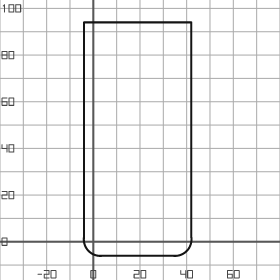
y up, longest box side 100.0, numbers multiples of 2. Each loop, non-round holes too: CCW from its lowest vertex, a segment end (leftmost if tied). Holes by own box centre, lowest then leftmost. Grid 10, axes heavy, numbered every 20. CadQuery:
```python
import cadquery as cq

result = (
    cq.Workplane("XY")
    .moveTo(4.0, -6.0)
    .lineTo(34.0, -6.0)
    .threePointArc((40.0, -4.0), (42.0, 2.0))
    .lineTo(42.0, 94.0)
    .lineTo(-4.0, 94.0)
    .lineTo(-4.0, 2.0)
    .threePointArc((-2.0, -4.0), (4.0, -6.0))
    .close()
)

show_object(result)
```